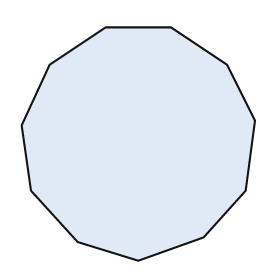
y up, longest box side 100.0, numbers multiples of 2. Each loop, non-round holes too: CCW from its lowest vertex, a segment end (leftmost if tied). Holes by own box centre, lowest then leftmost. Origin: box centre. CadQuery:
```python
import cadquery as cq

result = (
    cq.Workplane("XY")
    .moveTo(0.0, -50.0)
    .lineTo(28.0, -40.0)
    .lineTo(46.0, -20.0)
    .lineTo(50.0, 10.0)
    .lineTo(38.0, 34.0)
    .lineTo(14.0, 50.0)
    .lineTo(-14.0, 50.0)
    .lineTo(-38.0, 34.0)
    .lineTo(-50.0, 8.0)
    .lineTo(-46.0, -20.0)
    .lineTo(-26.0, -42.0)
    .close()
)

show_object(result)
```